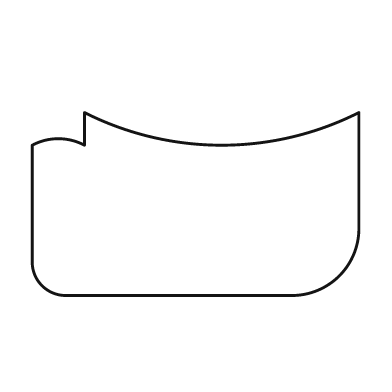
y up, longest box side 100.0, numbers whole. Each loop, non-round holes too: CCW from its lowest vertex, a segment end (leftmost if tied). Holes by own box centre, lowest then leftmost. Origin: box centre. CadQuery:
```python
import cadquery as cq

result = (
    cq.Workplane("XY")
    .moveTo(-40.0, -28.0)
    .lineTo(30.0, -28.0)
    .threePointArc((44.0, -22.0), (50.0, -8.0))
    .lineTo(50.0, 28.0)
    .threePointArc((8.0, 18.0), (-34.0, 28.0))
    .lineTo(-34.0, 18.0)
    .threePointArc((-42.0, 20.0), (-50.0, 18.0))
    .lineTo(-50.0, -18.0)
    .threePointArc((-47.0, -25.0), (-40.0, -28.0))
    .close()
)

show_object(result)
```